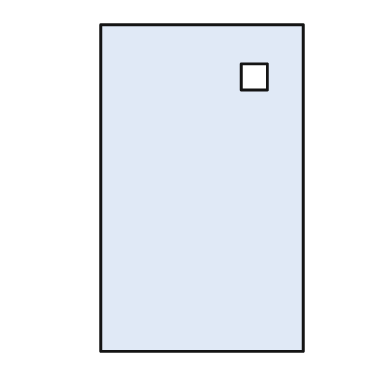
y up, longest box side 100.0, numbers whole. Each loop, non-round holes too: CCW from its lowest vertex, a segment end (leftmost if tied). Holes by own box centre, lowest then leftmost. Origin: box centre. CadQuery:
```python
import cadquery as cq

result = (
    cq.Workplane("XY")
    .moveTo(-31.0, -50.0)
    .lineTo(31.0, -50.0)
    .lineTo(31.0, 50.0)
    .lineTo(-31.0, 50.0)
    .close()
    .moveTo(12.0, 30.0)
    .lineTo(20.0, 30.0)
    .lineTo(20.0, 38.0)
    .lineTo(12.0, 38.0)
    .close()
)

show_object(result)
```